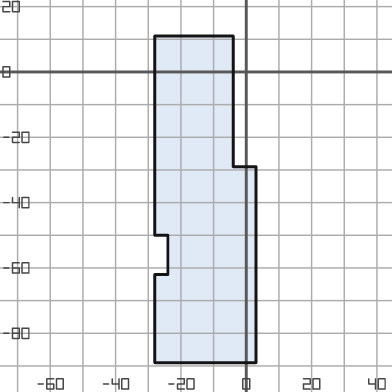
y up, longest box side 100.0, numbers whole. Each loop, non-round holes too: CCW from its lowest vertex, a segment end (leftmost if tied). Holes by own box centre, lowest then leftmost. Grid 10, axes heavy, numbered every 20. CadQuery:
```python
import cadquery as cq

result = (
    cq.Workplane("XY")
    .moveTo(-28.0, -89.0)
    .lineTo(3.0, -89.0)
    .lineTo(3.0, -29.0)
    .lineTo(-4.0, -29.0)
    .lineTo(-4.0, 11.0)
    .lineTo(-28.0, 11.0)
    .lineTo(-28.0, -50.0)
    .lineTo(-24.0, -50.0)
    .lineTo(-24.0, -62.0)
    .lineTo(-28.0, -62.0)
    .close()
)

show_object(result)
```